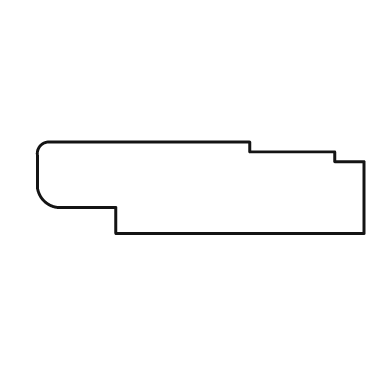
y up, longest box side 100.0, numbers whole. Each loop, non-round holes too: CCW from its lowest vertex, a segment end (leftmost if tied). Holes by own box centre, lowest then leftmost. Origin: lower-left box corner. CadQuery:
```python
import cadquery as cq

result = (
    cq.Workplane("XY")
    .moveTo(24.0, 0.0)
    .lineTo(100.0, 0.0)
    .lineTo(100.0, 22.0)
    .lineTo(91.0, 22.0)
    .lineTo(91.0, 25.0)
    .lineTo(65.0, 25.0)
    .lineTo(65.0, 28.0)
    .lineTo(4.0, 28.0)
    .threePointArc((1.0, 27.0), (0.0, 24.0))
    .lineTo(0.0, 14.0)
    .threePointArc((2.0, 10.0), (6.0, 8.0))
    .lineTo(24.0, 8.0)
    .close()
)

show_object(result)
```